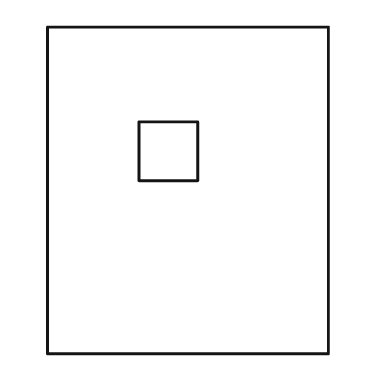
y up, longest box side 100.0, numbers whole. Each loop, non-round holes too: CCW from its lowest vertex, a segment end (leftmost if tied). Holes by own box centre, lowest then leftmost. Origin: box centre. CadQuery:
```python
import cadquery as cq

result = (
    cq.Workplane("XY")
    .moveTo(-43.0, -50.0)
    .lineTo(43.0, -50.0)
    .lineTo(43.0, 50.0)
    .lineTo(-43.0, 50.0)
    .close()
    .moveTo(-15.0, 3.0)
    .lineTo(3.0, 3.0)
    .lineTo(3.0, 21.0)
    .lineTo(-15.0, 21.0)
    .close()
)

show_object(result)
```